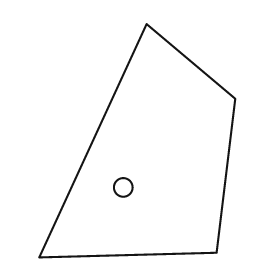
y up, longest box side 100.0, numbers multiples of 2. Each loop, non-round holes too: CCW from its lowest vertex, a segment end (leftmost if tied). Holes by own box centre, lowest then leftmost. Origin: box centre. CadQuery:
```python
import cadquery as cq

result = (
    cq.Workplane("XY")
    .moveTo(-42.0, -50.0)
    .lineTo(34.0, -48.0)
    .lineTo(42.0, 18.0)
    .lineTo(4.0, 50.0)
    .close()
    .moveTo(-6.0, -20.0)
    .circle(4.0)
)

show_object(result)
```